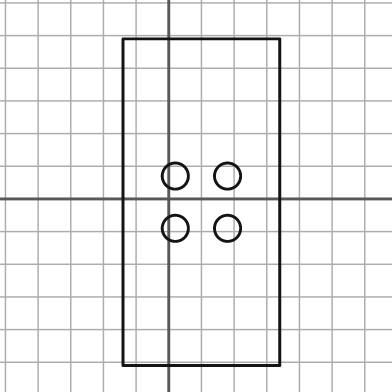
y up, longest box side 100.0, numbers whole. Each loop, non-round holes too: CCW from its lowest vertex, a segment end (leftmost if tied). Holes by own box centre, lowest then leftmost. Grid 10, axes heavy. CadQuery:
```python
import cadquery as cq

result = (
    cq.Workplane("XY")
    .moveTo(-14.0, -51.0)
    .lineTo(34.0, -51.0)
    .lineTo(34.0, 49.0)
    .lineTo(-14.0, 49.0)
    .close()
    .moveTo(2.0, -9.0)
    .circle(4.0)
    .moveTo(18.0, -9.0)
    .circle(4.0)
    .moveTo(2.0, 7.0)
    .circle(4.0)
    .moveTo(18.0, 7.0)
    .circle(4.0)
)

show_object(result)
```